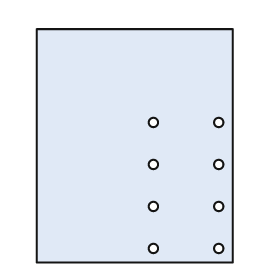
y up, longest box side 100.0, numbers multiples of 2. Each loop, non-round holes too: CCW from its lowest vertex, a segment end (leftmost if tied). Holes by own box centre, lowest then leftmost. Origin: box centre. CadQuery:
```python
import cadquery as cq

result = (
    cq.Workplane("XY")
    .moveTo(-42.0, -50.0)
    .lineTo(42.0, -50.0)
    .lineTo(42.0, 50.0)
    .lineTo(-42.0, 50.0)
    .close()
    .moveTo(8.0, -44.0)
    .circle(2.0)
    .moveTo(36.0, -44.0)
    .circle(2.0)
    .moveTo(8.0, -26.0)
    .circle(2.0)
    .moveTo(36.0, -26.0)
    .circle(2.0)
    .moveTo(8.0, -8.0)
    .circle(2.0)
    .moveTo(36.0, -8.0)
    .circle(2.0)
    .moveTo(8.0, 10.0)
    .circle(2.0)
    .moveTo(36.0, 10.0)
    .circle(2.0)
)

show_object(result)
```